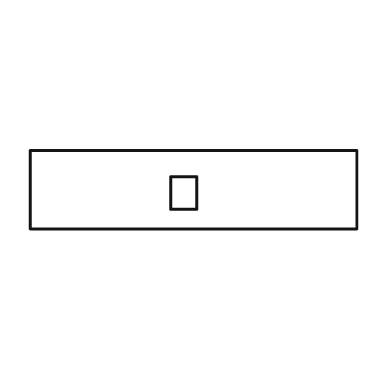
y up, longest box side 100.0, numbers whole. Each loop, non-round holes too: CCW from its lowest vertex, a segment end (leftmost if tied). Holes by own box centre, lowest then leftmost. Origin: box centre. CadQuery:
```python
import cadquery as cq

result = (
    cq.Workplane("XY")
    .moveTo(-50.0, -12.0)
    .lineTo(50.0, -12.0)
    .lineTo(50.0, 12.0)
    .lineTo(-50.0, 12.0)
    .close()
    .moveTo(-7.0, -6.0)
    .lineTo(1.0, -6.0)
    .lineTo(1.0, 4.0)
    .lineTo(-7.0, 4.0)
    .close()
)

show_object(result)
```